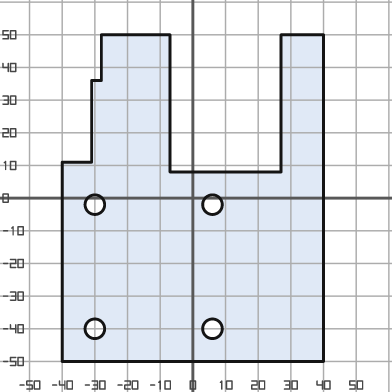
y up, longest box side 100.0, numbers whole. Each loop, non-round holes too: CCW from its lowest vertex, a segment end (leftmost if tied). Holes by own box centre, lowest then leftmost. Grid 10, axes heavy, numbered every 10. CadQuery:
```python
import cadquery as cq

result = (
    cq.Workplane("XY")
    .moveTo(-40.0, -50.0)
    .lineTo(40.0, -50.0)
    .lineTo(40.0, 50.0)
    .lineTo(27.0, 50.0)
    .lineTo(27.0, 8.0)
    .lineTo(-7.0, 8.0)
    .lineTo(-7.0, 50.0)
    .lineTo(-28.0, 50.0)
    .lineTo(-28.0, 36.0)
    .lineTo(-31.0, 36.0)
    .lineTo(-31.0, 11.0)
    .lineTo(-40.0, 11.0)
    .close()
    .moveTo(-30.0, -40.0)
    .circle(3.0)
    .moveTo(6.0, -40.0)
    .circle(3.0)
    .moveTo(-30.0, -2.0)
    .circle(3.0)
    .moveTo(6.0, -2.0)
    .circle(3.0)
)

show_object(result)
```